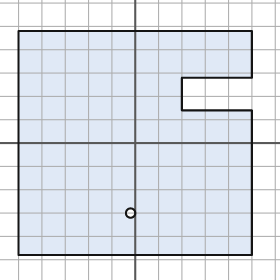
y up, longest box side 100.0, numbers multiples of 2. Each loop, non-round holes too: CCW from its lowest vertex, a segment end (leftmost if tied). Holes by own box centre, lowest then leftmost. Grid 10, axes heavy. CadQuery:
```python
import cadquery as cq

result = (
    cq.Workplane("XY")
    .moveTo(-50.0, -48.0)
    .lineTo(50.0, -48.0)
    .lineTo(50.0, 14.0)
    .lineTo(20.0, 14.0)
    .lineTo(20.0, 28.0)
    .lineTo(50.0, 28.0)
    .lineTo(50.0, 48.0)
    .lineTo(-50.0, 48.0)
    .close()
    .moveTo(-2.0, -30.0)
    .circle(2.0)
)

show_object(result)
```